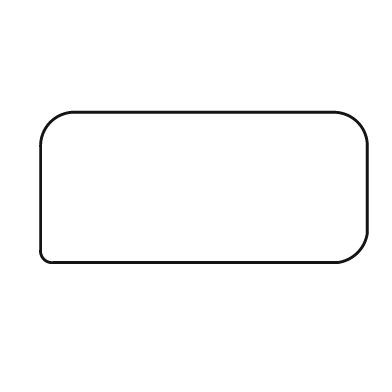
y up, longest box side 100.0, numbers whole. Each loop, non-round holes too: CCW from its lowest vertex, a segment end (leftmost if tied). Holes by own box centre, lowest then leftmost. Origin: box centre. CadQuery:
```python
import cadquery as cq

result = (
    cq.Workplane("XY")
    .moveTo(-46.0, -23.0)
    .lineTo(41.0, -23.0)
    .threePointArc((47.0, -20.0), (50.0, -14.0))
    .lineTo(50.0, 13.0)
    .threePointArc((47.0, 20.0), (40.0, 23.0))
    .lineTo(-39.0, 23.0)
    .threePointArc((-47.0, 20.0), (-50.0, 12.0))
    .lineTo(-50.0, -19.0)
    .threePointArc((-49.0, -22.0), (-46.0, -23.0))
    .close()
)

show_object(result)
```